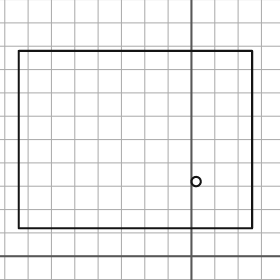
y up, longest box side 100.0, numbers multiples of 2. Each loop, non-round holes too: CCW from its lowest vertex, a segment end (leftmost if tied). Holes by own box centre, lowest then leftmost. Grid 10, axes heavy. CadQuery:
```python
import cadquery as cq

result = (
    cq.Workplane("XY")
    .moveTo(-74.0, 12.0)
    .lineTo(26.0, 12.0)
    .lineTo(26.0, 88.0)
    .lineTo(-74.0, 88.0)
    .close()
    .moveTo(2.0, 32.0)
    .circle(2.0)
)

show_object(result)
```